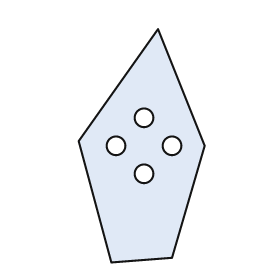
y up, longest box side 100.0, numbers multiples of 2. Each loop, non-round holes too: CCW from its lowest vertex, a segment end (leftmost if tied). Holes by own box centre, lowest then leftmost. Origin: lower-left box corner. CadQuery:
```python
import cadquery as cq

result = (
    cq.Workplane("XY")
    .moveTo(14.0, 0.0)
    .lineTo(40.0, 2.0)
    .lineTo(54.0, 50.0)
    .lineTo(34.0, 100.0)
    .lineTo(0.0, 52.0)
    .close()
    .moveTo(28.0, 38.0)
    .circle(4.0)
    .moveTo(16.0, 50.0)
    .circle(4.0)
    .moveTo(40.0, 50.0)
    .circle(4.0)
    .moveTo(28.0, 62.0)
    .circle(4.0)
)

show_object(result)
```